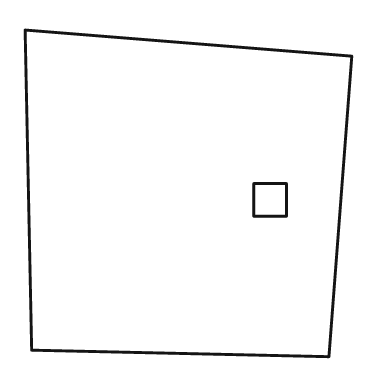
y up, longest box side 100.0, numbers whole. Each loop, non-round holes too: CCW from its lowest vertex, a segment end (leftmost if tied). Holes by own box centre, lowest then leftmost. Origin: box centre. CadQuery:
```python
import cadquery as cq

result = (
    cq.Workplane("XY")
    .moveTo(43.0, -50.0)
    .lineTo(50.0, 42.0)
    .lineTo(-50.0, 50.0)
    .lineTo(-48.0, -48.0)
    .close()
    .moveTo(20.0, -7.0)
    .lineTo(30.0, -7.0)
    .lineTo(30.0, 3.0)
    .lineTo(20.0, 3.0)
    .close()
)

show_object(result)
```